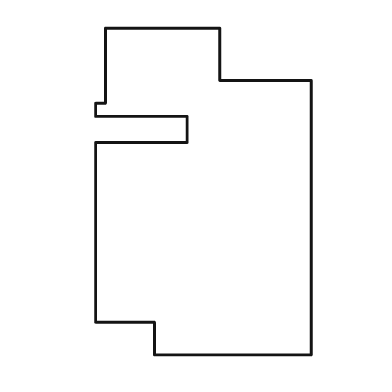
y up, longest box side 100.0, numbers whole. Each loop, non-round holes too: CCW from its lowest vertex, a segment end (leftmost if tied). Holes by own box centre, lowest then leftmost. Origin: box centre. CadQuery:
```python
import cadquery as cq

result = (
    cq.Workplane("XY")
    .moveTo(-15.0, -50.0)
    .lineTo(33.0, -50.0)
    .lineTo(33.0, 34.0)
    .lineTo(5.0, 34.0)
    .lineTo(5.0, 50.0)
    .lineTo(-30.0, 50.0)
    .lineTo(-30.0, 27.0)
    .lineTo(-33.0, 27.0)
    .lineTo(-33.0, 23.0)
    .lineTo(-5.0, 23.0)
    .lineTo(-5.0, 15.0)
    .lineTo(-33.0, 15.0)
    .lineTo(-33.0, -40.0)
    .lineTo(-15.0, -40.0)
    .close()
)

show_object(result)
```